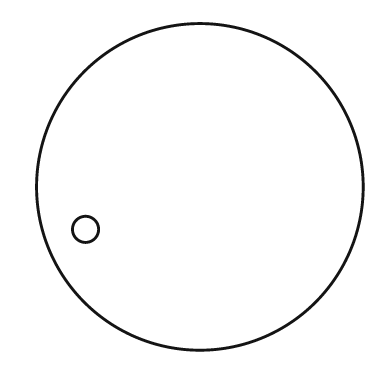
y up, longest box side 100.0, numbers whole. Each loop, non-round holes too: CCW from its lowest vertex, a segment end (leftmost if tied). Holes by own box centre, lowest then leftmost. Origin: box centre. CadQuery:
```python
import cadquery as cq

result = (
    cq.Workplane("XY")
    .moveTo(0.0, 0.0)
    .circle(50.0)
    .moveTo(-35.0, -13.0)
    .circle(4.0)
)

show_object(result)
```